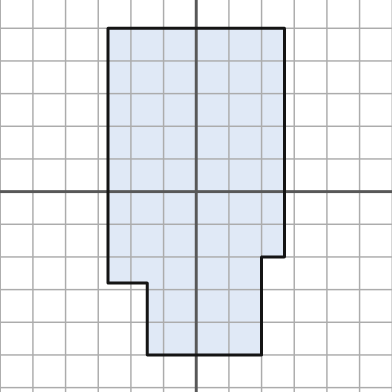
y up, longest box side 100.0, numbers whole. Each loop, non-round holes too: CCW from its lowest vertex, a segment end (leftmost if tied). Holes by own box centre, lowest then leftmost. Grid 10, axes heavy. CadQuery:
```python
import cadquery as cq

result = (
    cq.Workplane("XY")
    .moveTo(-15.0, -50.0)
    .lineTo(20.0, -50.0)
    .lineTo(20.0, -20.0)
    .lineTo(27.0, -20.0)
    .lineTo(27.0, 50.0)
    .lineTo(-27.0, 50.0)
    .lineTo(-27.0, -28.0)
    .lineTo(-15.0, -28.0)
    .close()
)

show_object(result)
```